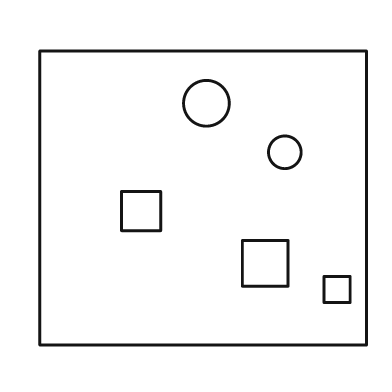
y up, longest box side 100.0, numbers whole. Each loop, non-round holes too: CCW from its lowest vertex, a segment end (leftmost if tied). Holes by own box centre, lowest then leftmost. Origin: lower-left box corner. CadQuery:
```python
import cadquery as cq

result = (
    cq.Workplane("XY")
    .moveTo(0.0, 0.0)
    .lineTo(100.0, 0.0)
    .lineTo(100.0, 90.0)
    .lineTo(0.0, 90.0)
    .close()
    .moveTo(87.0, 13.0)
    .lineTo(95.0, 13.0)
    .lineTo(95.0, 21.0)
    .lineTo(87.0, 21.0)
    .close()
    .moveTo(62.0, 18.0)
    .lineTo(76.0, 18.0)
    .lineTo(76.0, 32.0)
    .lineTo(62.0, 32.0)
    .close()
    .moveTo(25.0, 35.0)
    .lineTo(37.0, 35.0)
    .lineTo(37.0, 47.0)
    .lineTo(25.0, 47.0)
    .close()
    .moveTo(75.0, 59.0)
    .circle(5.0)
    .moveTo(51.0, 74.0)
    .circle(7.0)
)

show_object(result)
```